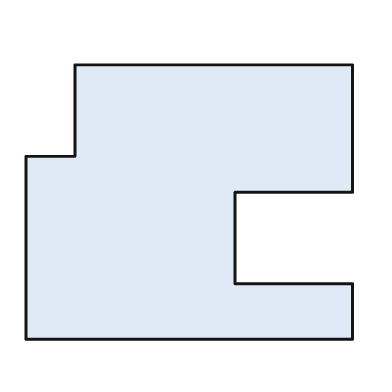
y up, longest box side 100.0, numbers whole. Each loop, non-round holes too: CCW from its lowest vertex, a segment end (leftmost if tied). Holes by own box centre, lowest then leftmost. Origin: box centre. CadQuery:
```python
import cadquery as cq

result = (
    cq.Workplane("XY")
    .moveTo(-50.0, -42.0)
    .lineTo(50.0, -42.0)
    .lineTo(50.0, -25.0)
    .lineTo(14.0, -25.0)
    .lineTo(14.0, 3.0)
    .lineTo(50.0, 3.0)
    .lineTo(50.0, 42.0)
    .lineTo(-35.0, 42.0)
    .lineTo(-35.0, 14.0)
    .lineTo(-50.0, 14.0)
    .close()
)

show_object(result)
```